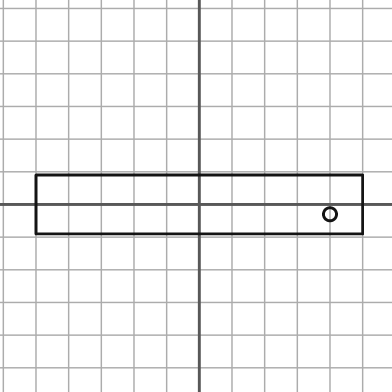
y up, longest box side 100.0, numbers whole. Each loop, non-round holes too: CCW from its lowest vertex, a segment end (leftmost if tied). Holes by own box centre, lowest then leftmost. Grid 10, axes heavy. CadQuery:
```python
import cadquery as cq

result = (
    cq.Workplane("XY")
    .moveTo(-50.0, -9.0)
    .lineTo(50.0, -9.0)
    .lineTo(50.0, 9.0)
    .lineTo(-50.0, 9.0)
    .close()
    .moveTo(40.0, -3.0)
    .circle(2.0)
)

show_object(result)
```